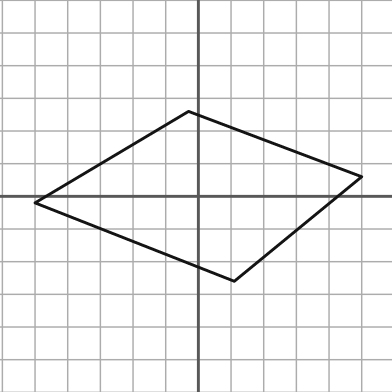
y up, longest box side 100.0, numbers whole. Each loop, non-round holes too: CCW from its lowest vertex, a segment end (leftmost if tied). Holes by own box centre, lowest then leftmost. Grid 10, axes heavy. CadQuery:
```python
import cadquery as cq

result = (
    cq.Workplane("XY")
    .moveTo(11.0, -26.0)
    .lineTo(50.0, 6.0)
    .lineTo(-3.0, 26.0)
    .lineTo(-50.0, -2.0)
    .close()
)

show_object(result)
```